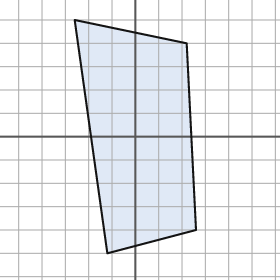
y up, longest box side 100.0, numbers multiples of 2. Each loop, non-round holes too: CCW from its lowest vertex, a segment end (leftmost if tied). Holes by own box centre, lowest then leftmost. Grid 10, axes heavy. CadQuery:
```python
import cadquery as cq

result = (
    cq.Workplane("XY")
    .moveTo(-12.0, -50.0)
    .lineTo(26.0, -40.0)
    .lineTo(22.0, 40.0)
    .lineTo(-26.0, 50.0)
    .close()
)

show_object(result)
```